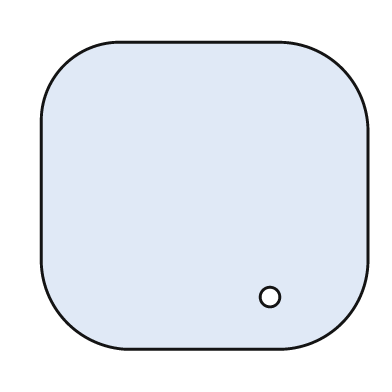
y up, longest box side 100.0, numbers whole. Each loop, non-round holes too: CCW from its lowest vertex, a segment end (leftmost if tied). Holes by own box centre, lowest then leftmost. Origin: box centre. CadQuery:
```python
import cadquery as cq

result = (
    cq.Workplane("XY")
    .moveTo(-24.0, -47.0)
    .lineTo(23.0, -47.0)
    .threePointArc((42.0, -39.0), (50.0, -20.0))
    .lineTo(50.0, 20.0)
    .threePointArc((42.0, 39.0), (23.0, 47.0))
    .lineTo(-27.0, 47.0)
    .threePointArc((-43.0, 40.0), (-50.0, 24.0))
    .lineTo(-50.0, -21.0)
    .threePointArc((-42.0, -39.0), (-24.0, -47.0))
    .close()
    .moveTo(20.0, -31.0)
    .circle(3.0)
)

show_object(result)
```